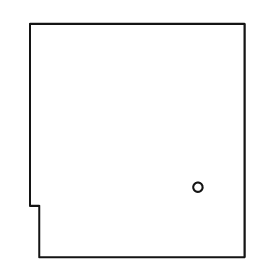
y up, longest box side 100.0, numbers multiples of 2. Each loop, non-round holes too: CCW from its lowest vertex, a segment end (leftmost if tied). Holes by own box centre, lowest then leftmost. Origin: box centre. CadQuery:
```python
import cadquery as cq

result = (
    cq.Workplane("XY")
    .moveTo(-42.0, -50.0)
    .lineTo(46.0, -50.0)
    .lineTo(46.0, 50.0)
    .lineTo(-46.0, 50.0)
    .lineTo(-46.0, -28.0)
    .lineTo(-42.0, -28.0)
    .close()
    .moveTo(26.0, -20.0)
    .circle(2.0)
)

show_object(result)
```